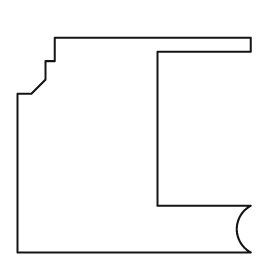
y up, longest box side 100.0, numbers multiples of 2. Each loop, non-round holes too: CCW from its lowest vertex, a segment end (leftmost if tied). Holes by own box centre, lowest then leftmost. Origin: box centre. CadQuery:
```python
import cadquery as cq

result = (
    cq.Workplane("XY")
    .moveTo(-50.0, -46.0)
    .lineTo(50.0, -46.0)
    .threePointArc((44.0, -36.0), (50.0, -26.0))
    .lineTo(10.0, -26.0)
    .lineTo(10.0, 40.0)
    .lineTo(50.0, 40.0)
    .lineTo(50.0, 46.0)
    .lineTo(-34.0, 46.0)
    .lineTo(-34.0, 36.0)
    .lineTo(-38.0, 36.0)
    .lineTo(-38.0, 28.0)
    .lineTo(-44.0, 22.0)
    .lineTo(-50.0, 22.0)
    .close()
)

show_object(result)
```